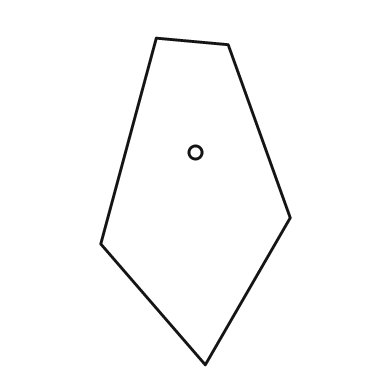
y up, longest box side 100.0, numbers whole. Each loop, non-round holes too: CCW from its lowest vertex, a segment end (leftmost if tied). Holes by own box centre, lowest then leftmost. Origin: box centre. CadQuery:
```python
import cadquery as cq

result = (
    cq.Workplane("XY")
    .moveTo(3.0, -50.0)
    .lineTo(29.0, -5.0)
    .lineTo(10.0, 48.0)
    .lineTo(-12.0, 50.0)
    .lineTo(-29.0, -13.0)
    .close()
    .moveTo(0.0, 15.0)
    .circle(2.0)
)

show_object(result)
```